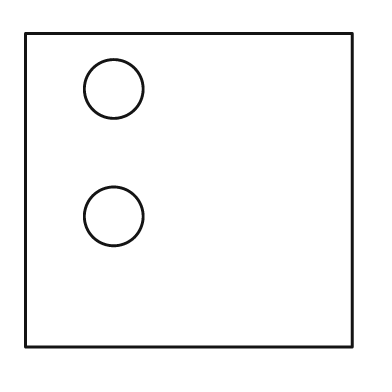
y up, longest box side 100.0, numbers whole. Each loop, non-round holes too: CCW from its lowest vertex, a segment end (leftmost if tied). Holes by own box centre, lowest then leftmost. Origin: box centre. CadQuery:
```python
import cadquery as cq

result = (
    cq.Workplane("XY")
    .moveTo(-50.0, -48.0)
    .lineTo(50.0, -48.0)
    .lineTo(50.0, 48.0)
    .lineTo(-50.0, 48.0)
    .close()
    .moveTo(-23.0, -8.0)
    .circle(9.0)
    .moveTo(-23.0, 31.0)
    .circle(9.0)
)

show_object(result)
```